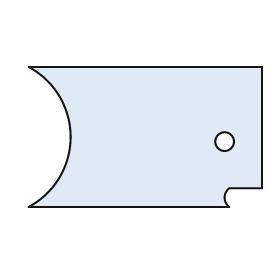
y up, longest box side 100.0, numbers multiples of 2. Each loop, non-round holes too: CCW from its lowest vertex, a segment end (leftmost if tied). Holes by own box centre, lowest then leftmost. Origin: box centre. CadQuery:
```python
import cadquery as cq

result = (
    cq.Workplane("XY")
    .moveTo(-50.0, -30.0)
    .lineTo(36.0, -30.0)
    .threePointArc((34.0, -26.0), (36.0, -22.0))
    .lineTo(50.0, -22.0)
    .lineTo(50.0, 30.0)
    .lineTo(-50.0, 30.0)
    .threePointArc((-32.0, 0.0), (-50.0, -30.0))
    .close()
    .moveTo(34.0, -2.0)
    .circle(4.0)
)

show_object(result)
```